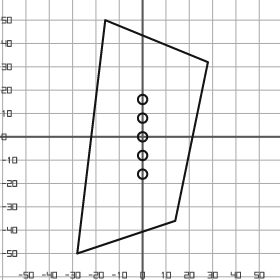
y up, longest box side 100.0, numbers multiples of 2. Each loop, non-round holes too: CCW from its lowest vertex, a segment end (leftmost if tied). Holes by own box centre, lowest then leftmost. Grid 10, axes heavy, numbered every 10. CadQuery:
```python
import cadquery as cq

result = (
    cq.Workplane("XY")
    .moveTo(-28.0, -50.0)
    .lineTo(14.0, -36.0)
    .lineTo(28.0, 32.0)
    .lineTo(-16.0, 50.0)
    .close()
    .moveTo(0.0, -16.0)
    .circle(2.0)
    .moveTo(0.0, -8.0)
    .circle(2.0)
    .moveTo(0.0, 0.0)
    .circle(2.0)
    .moveTo(0.0, 8.0)
    .circle(2.0)
    .moveTo(0.0, 16.0)
    .circle(2.0)
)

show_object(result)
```